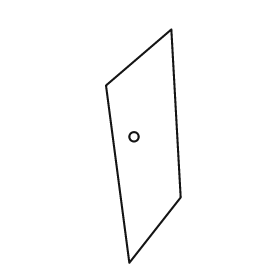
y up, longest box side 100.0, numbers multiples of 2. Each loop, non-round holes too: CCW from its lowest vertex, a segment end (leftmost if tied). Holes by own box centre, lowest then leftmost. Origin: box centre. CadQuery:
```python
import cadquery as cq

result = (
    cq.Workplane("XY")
    .moveTo(-6.0, -50.0)
    .lineTo(16.0, -22.0)
    .lineTo(12.0, 50.0)
    .lineTo(-16.0, 26.0)
    .close()
    .moveTo(-4.0, 4.0)
    .circle(2.0)
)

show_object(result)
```